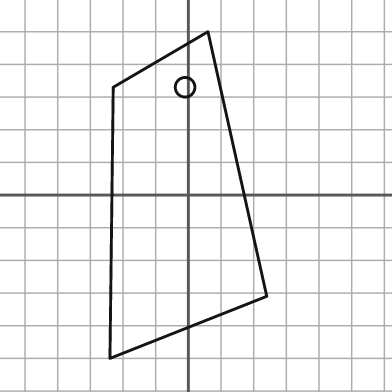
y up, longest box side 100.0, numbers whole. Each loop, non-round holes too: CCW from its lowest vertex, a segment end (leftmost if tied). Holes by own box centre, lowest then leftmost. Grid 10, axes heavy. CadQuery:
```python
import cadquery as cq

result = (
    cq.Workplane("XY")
    .moveTo(-24.0, -50.0)
    .lineTo(24.0, -31.0)
    .lineTo(6.0, 50.0)
    .lineTo(-23.0, 33.0)
    .close()
    .moveTo(-1.0, 33.0)
    .circle(3.0)
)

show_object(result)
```